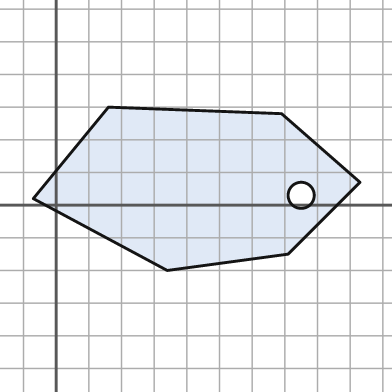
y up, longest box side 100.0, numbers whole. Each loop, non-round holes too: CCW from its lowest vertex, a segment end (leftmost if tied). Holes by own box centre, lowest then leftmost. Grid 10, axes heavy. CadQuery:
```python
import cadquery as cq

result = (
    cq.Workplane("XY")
    .moveTo(34.0, -20.0)
    .lineTo(71.0, -15.0)
    .lineTo(93.0, 7.0)
    .lineTo(69.0, 28.0)
    .lineTo(16.0, 30.0)
    .lineTo(-7.0, 2.0)
    .close()
    .moveTo(75.0, 3.0)
    .circle(4.0)
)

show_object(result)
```